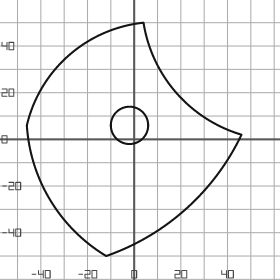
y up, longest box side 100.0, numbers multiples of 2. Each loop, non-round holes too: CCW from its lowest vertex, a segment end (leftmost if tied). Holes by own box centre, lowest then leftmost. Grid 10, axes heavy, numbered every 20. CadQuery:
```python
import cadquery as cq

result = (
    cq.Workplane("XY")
    .moveTo(-12.0, -50.0)
    .threePointArc((22.0, -30.0), (46.0, 2.0))
    .threePointArc((18.0, 20.0), (4.0, 50.0))
    .threePointArc((-28.0, 36.0), (-46.0, 6.0))
    .threePointArc((-36.0, -26.0), (-12.0, -50.0))
    .close()
    .moveTo(-2.0, 6.0)
    .circle(8.0)
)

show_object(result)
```